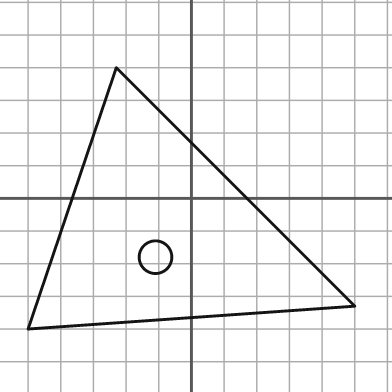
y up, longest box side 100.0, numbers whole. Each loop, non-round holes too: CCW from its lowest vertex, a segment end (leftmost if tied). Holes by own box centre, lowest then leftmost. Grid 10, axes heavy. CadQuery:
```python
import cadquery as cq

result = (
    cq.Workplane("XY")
    .moveTo(-50.0, -40.0)
    .lineTo(50.0, -33.0)
    .lineTo(-23.0, 40.0)
    .close()
    .moveTo(-11.0, -18.0)
    .circle(5.0)
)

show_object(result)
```